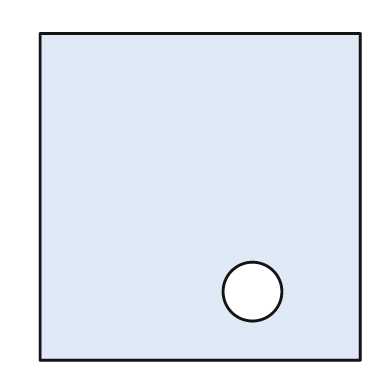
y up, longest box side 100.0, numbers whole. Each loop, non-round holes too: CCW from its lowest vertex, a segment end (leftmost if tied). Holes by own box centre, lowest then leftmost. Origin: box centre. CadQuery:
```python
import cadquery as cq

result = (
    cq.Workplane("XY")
    .moveTo(-49.0, -50.0)
    .lineTo(49.0, -50.0)
    .lineTo(49.0, 50.0)
    .lineTo(-49.0, 50.0)
    .close()
    .moveTo(16.0, -29.0)
    .circle(9.0)
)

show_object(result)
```